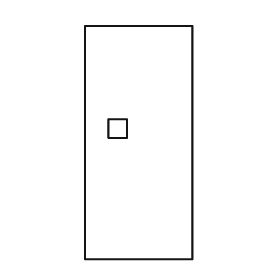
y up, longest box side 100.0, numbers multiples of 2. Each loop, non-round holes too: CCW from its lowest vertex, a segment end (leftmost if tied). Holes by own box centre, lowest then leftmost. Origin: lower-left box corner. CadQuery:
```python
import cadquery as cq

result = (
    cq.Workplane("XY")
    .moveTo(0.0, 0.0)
    .lineTo(46.0, 0.0)
    .lineTo(46.0, 100.0)
    .lineTo(0.0, 100.0)
    .close()
    .moveTo(10.0, 52.0)
    .lineTo(18.0, 52.0)
    .lineTo(18.0, 60.0)
    .lineTo(10.0, 60.0)
    .close()
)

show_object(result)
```